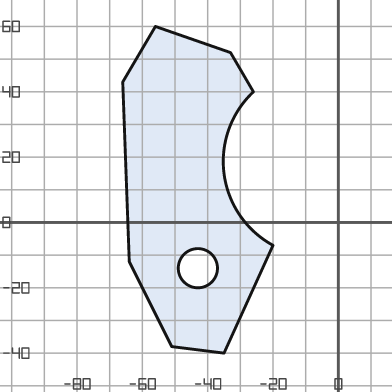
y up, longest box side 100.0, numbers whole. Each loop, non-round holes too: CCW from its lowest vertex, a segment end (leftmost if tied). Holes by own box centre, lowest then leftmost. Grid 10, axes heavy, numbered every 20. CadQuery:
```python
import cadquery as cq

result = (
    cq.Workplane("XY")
    .moveTo(-35.0, -40.0)
    .lineTo(-20.0, -7.0)
    .threePointArc((-35.0, 15.0), (-26.0, 40.0))
    .lineTo(-33.0, 52.0)
    .lineTo(-56.0, 60.0)
    .lineTo(-66.0, 43.0)
    .lineTo(-64.0, -12.0)
    .lineTo(-51.0, -38.0)
    .close()
    .moveTo(-43.0, -14.0)
    .circle(6.0)
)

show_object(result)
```